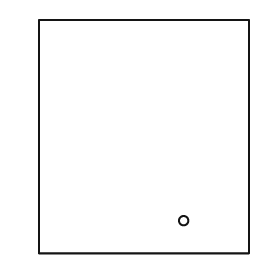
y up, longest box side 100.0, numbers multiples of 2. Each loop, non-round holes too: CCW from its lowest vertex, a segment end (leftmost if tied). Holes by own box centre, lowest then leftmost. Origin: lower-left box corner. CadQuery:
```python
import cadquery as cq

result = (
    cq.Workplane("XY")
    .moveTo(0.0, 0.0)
    .lineTo(90.0, 0.0)
    .lineTo(90.0, 100.0)
    .lineTo(0.0, 100.0)
    .close()
    .moveTo(62.0, 14.0)
    .circle(2.0)
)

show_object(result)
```